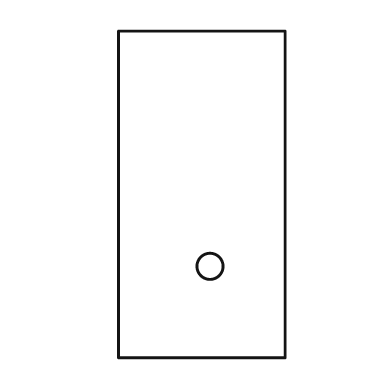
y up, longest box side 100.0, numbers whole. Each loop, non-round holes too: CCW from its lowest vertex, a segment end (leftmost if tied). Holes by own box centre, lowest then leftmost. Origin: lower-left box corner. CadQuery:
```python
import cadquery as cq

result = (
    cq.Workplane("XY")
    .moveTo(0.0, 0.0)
    .lineTo(51.0, 0.0)
    .lineTo(51.0, 100.0)
    .lineTo(0.0, 100.0)
    .close()
    .moveTo(28.0, 28.0)
    .circle(4.0)
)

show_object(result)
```